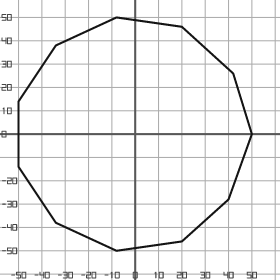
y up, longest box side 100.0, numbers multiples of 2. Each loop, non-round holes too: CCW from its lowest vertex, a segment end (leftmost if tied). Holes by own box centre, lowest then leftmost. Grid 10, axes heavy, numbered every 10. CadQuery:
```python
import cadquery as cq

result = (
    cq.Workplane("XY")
    .moveTo(-8.0, -50.0)
    .lineTo(20.0, -46.0)
    .lineTo(40.0, -28.0)
    .lineTo(50.0, 0.0)
    .lineTo(42.0, 26.0)
    .lineTo(20.0, 46.0)
    .lineTo(-8.0, 50.0)
    .lineTo(-34.0, 38.0)
    .lineTo(-50.0, 14.0)
    .lineTo(-50.0, -14.0)
    .lineTo(-34.0, -38.0)
    .close()
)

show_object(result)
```